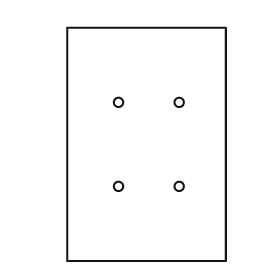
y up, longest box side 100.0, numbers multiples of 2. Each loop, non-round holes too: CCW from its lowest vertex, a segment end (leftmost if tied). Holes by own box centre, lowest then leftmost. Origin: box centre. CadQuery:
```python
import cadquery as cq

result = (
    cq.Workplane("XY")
    .moveTo(-34.0, -50.0)
    .lineTo(34.0, -50.0)
    .lineTo(34.0, 50.0)
    .lineTo(-34.0, 50.0)
    .close()
    .moveTo(-12.0, -18.0)
    .circle(2.0)
    .moveTo(14.0, -18.0)
    .circle(2.0)
    .moveTo(-12.0, 18.0)
    .circle(2.0)
    .moveTo(14.0, 18.0)
    .circle(2.0)
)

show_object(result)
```